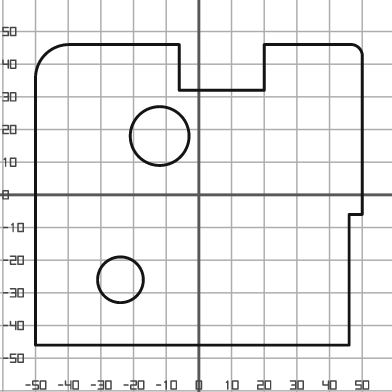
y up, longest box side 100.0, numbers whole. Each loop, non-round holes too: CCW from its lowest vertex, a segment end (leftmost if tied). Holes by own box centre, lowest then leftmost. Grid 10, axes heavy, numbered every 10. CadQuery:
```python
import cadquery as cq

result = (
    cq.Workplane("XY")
    .moveTo(-50.0, -46.0)
    .lineTo(46.0, -46.0)
    .lineTo(46.0, -6.0)
    .lineTo(50.0, -6.0)
    .lineTo(50.0, 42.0)
    .threePointArc((49.0, 45.0), (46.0, 46.0))
    .lineTo(20.0, 46.0)
    .lineTo(20.0, 32.0)
    .lineTo(-6.0, 32.0)
    .lineTo(-6.0, 46.0)
    .lineTo(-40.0, 46.0)
    .threePointArc((-47.0, 43.0), (-50.0, 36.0))
    .close()
    .moveTo(-24.0, -26.0)
    .circle(7.0)
    .moveTo(-12.0, 18.0)
    .circle(9.0)
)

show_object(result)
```